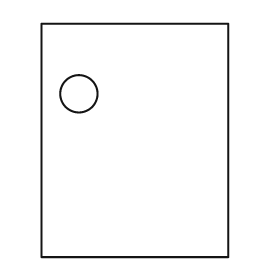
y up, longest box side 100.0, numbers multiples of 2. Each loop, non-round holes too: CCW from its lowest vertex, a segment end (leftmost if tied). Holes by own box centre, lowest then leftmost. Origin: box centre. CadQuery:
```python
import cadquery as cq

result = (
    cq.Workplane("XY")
    .moveTo(-40.0, -50.0)
    .lineTo(40.0, -50.0)
    .lineTo(40.0, 50.0)
    .lineTo(-40.0, 50.0)
    .close()
    .moveTo(-24.0, 20.0)
    .circle(8.0)
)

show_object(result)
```